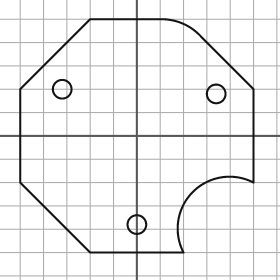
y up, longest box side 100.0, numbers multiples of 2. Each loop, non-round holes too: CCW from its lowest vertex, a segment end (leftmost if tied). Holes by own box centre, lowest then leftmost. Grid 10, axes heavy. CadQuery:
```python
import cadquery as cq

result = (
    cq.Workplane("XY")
    .moveTo(-20.0, -50.0)
    .lineTo(20.0, -50.0)
    .threePointArc((24.0, -24.0), (50.0, -20.0))
    .lineTo(50.0, 20.0)
    .lineTo(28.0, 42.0)
    .threePointArc((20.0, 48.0), (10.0, 50.0))
    .lineTo(-20.0, 50.0)
    .lineTo(-50.0, 20.0)
    .lineTo(-50.0, -20.0)
    .close()
    .moveTo(0.0, -38.0)
    .circle(4.0)
    .moveTo(34.0, 18.0)
    .circle(4.0)
    .moveTo(-32.0, 20.0)
    .circle(4.0)
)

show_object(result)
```